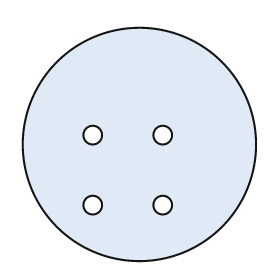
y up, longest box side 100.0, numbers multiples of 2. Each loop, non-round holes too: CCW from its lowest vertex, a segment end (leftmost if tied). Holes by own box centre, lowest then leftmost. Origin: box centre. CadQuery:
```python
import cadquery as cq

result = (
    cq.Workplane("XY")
    .moveTo(0.0, 0.0)
    .circle(50.0)
    .moveTo(-20.0, -26.0)
    .circle(4.0)
    .moveTo(10.0, -26.0)
    .circle(4.0)
    .moveTo(-20.0, 4.0)
    .circle(4.0)
    .moveTo(10.0, 4.0)
    .circle(4.0)
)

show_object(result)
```